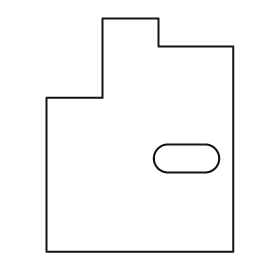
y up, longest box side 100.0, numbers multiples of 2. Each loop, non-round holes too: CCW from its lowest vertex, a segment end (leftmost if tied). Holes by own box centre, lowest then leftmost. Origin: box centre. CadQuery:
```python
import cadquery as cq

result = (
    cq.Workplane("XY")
    .moveTo(-40.0, -50.0)
    .lineTo(40.0, -50.0)
    .lineTo(40.0, 38.0)
    .lineTo(8.0, 38.0)
    .lineTo(8.0, 50.0)
    .lineTo(-16.0, 50.0)
    .lineTo(-16.0, 16.0)
    .lineTo(-40.0, 16.0)
    .close()
    .moveTo(12.0, -16.0)
    .lineTo(28.0, -16.0)
    .threePointArc((34.0, -10.0), (28.0, -4.0))
    .lineTo(12.0, -4.0)
    .threePointArc((6.0, -10.0), (12.0, -16.0))
    .close()
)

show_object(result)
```